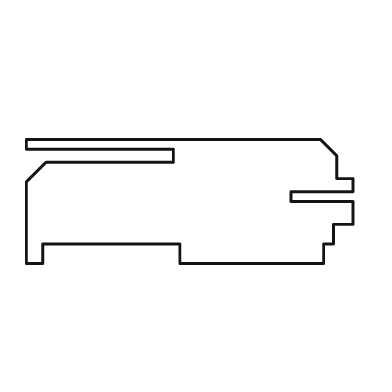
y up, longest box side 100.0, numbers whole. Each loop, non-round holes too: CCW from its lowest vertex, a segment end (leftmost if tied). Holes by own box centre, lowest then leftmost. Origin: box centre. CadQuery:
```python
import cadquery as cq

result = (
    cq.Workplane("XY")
    .moveTo(-50.0, -19.0)
    .lineTo(-45.0, -19.0)
    .lineTo(-45.0, -13.0)
    .lineTo(-3.0, -13.0)
    .lineTo(-3.0, -19.0)
    .lineTo(41.0, -19.0)
    .lineTo(41.0, -13.0)
    .lineTo(44.0, -13.0)
    .lineTo(44.0, -7.0)
    .lineTo(50.0, -7.0)
    .lineTo(50.0, 0.0)
    .lineTo(31.0, 0.0)
    .lineTo(31.0, 3.0)
    .lineTo(50.0, 3.0)
    .lineTo(50.0, 7.0)
    .lineTo(45.0, 7.0)
    .lineTo(45.0, 14.0)
    .lineTo(40.0, 19.0)
    .lineTo(-50.0, 19.0)
    .lineTo(-50.0, 16.0)
    .lineTo(-5.0, 16.0)
    .lineTo(-5.0, 12.0)
    .lineTo(-44.0, 12.0)
    .lineTo(-50.0, 6.0)
    .close()
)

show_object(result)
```